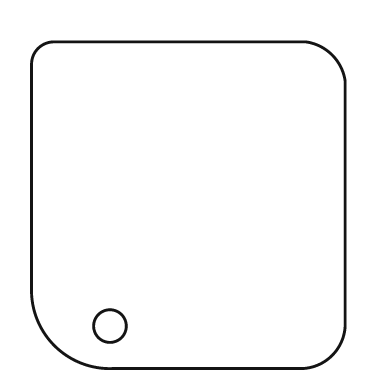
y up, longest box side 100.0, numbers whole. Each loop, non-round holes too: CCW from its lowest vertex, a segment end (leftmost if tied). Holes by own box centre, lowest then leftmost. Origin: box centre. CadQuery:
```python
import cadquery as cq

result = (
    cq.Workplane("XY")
    .moveTo(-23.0, -50.0)
    .lineTo(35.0, -50.0)
    .threePointArc((44.0, -46.0), (48.0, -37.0))
    .lineTo(48.0, 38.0)
    .threePointArc((44.0, 46.0), (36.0, 50.0))
    .lineTo(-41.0, 50.0)
    .threePointArc((-46.0, 48.0), (-48.0, 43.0))
    .lineTo(-48.0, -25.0)
    .threePointArc((-41.0, -43.0), (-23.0, -50.0))
    .close()
    .moveTo(-24.0, -37.0)
    .circle(5.0)
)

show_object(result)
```